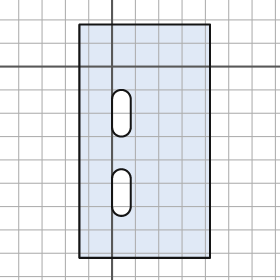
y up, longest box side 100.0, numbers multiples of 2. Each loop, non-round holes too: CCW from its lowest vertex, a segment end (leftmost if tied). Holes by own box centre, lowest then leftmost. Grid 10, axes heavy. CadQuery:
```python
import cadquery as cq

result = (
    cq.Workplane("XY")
    .moveTo(-14.0, -82.0)
    .lineTo(42.0, -82.0)
    .lineTo(42.0, 18.0)
    .lineTo(-14.0, 18.0)
    .close()
    .moveTo(0.0, -60.0)
    .threePointArc((4.0, -64.0), (8.0, -60.0))
    .lineTo(8.0, -48.0)
    .threePointArc((4.0, -44.0), (0.0, -48.0))
    .close()
    .moveTo(0.0, -26.0)
    .threePointArc((4.0, -30.0), (8.0, -26.0))
    .lineTo(8.0, -14.0)
    .threePointArc((4.0, -10.0), (0.0, -14.0))
    .close()
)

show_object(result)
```